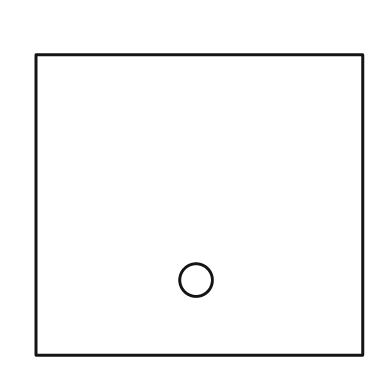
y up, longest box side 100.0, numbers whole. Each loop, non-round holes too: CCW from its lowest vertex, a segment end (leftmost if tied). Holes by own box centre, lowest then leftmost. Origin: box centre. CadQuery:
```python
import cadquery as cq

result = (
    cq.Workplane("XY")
    .moveTo(-50.0, -46.0)
    .lineTo(50.0, -46.0)
    .lineTo(50.0, 46.0)
    .lineTo(-50.0, 46.0)
    .close()
    .moveTo(-1.0, -23.0)
    .circle(5.0)
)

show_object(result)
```